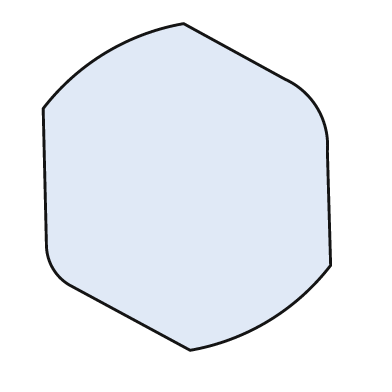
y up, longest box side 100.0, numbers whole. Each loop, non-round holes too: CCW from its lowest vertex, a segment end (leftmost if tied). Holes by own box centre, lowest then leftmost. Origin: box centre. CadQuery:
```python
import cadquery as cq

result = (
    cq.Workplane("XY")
    .moveTo(1.0, -50.0)
    .threePointArc((25.0, -41.0), (44.0, -24.0))
    .lineTo(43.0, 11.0)
    .threePointArc((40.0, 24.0), (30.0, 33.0))
    .lineTo(-1.0, 50.0)
    .threePointArc((-25.0, 41.0), (-44.0, 24.0))
    .lineTo(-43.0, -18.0)
    .threePointArc((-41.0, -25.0), (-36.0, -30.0))
    .close()
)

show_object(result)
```